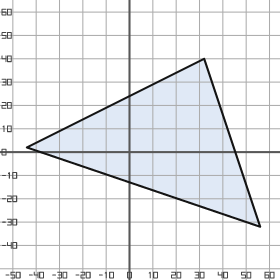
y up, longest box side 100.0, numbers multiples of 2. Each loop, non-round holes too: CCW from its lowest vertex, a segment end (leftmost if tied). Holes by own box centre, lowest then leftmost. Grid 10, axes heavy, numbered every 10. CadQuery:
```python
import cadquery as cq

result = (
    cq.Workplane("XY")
    .moveTo(56.0, -32.0)
    .lineTo(32.0, 40.0)
    .lineTo(-44.0, 2.0)
    .close()
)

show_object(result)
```